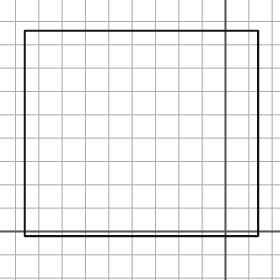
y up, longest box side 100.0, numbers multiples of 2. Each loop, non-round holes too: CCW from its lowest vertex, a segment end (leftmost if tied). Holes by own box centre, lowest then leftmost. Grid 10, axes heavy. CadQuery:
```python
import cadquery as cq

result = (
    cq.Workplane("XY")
    .moveTo(-86.0, -2.0)
    .lineTo(14.0, -2.0)
    .lineTo(14.0, 86.0)
    .lineTo(-86.0, 86.0)
    .close()
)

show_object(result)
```